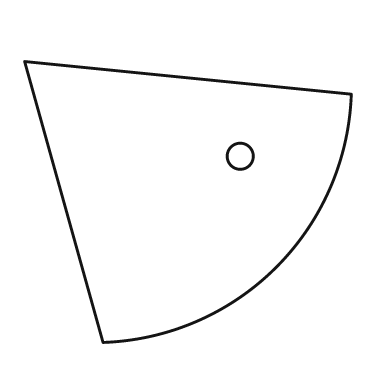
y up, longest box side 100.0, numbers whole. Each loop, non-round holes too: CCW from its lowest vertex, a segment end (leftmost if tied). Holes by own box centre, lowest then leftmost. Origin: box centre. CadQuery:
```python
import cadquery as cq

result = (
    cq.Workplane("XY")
    .moveTo(-26.0, -43.0)
    .threePointArc((27.0, -20.0), (50.0, 33.0))
    .lineTo(-50.0, 43.0)
    .close()
    .moveTo(16.0, 14.0)
    .circle(4.0)
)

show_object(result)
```